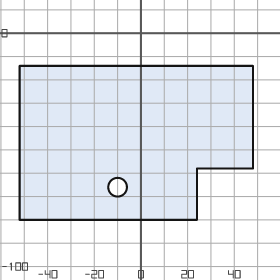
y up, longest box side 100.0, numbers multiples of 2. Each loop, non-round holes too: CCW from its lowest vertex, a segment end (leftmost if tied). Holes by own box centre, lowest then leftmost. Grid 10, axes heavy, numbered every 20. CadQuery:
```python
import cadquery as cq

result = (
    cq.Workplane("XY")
    .moveTo(-52.0, -80.0)
    .lineTo(24.0, -80.0)
    .lineTo(24.0, -58.0)
    .lineTo(48.0, -58.0)
    .lineTo(48.0, -14.0)
    .lineTo(-52.0, -14.0)
    .close()
    .moveTo(-10.0, -66.0)
    .circle(4.0)
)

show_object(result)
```